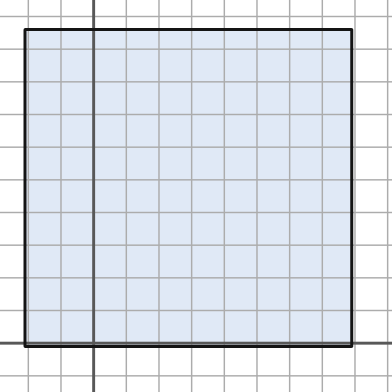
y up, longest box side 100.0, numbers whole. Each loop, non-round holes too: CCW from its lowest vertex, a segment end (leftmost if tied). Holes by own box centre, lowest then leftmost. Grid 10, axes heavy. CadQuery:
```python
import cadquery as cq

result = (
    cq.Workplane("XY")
    .moveTo(-21.0, -1.0)
    .lineTo(79.0, -1.0)
    .lineTo(79.0, 96.0)
    .lineTo(-21.0, 96.0)
    .close()
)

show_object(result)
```